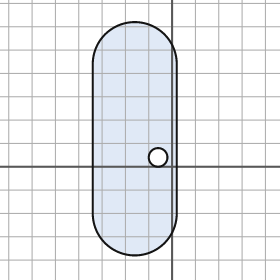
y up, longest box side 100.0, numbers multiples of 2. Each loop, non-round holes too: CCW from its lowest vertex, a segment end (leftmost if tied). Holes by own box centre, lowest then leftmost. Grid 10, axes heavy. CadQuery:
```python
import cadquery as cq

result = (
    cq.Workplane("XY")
    .moveTo(-34.0, -20.0)
    .threePointArc((-16.0, -38.0), (2.0, -20.0))
    .lineTo(2.0, 44.0)
    .threePointArc((-16.0, 62.0), (-34.0, 44.0))
    .close()
    .moveTo(-6.0, 4.0)
    .circle(4.0)
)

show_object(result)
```